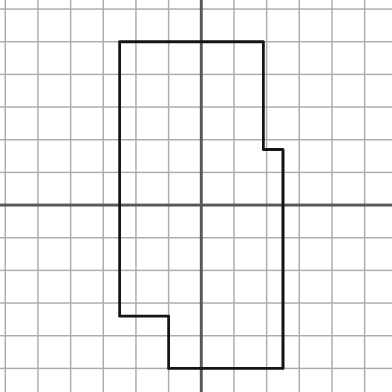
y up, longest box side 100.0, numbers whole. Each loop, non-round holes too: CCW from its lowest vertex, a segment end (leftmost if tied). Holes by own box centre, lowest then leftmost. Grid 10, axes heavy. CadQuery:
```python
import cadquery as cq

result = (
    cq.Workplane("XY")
    .moveTo(-10.0, -50.0)
    .lineTo(25.0, -50.0)
    .lineTo(25.0, 17.0)
    .lineTo(19.0, 17.0)
    .lineTo(19.0, 50.0)
    .lineTo(-25.0, 50.0)
    .lineTo(-25.0, -34.0)
    .lineTo(-10.0, -34.0)
    .close()
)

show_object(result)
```